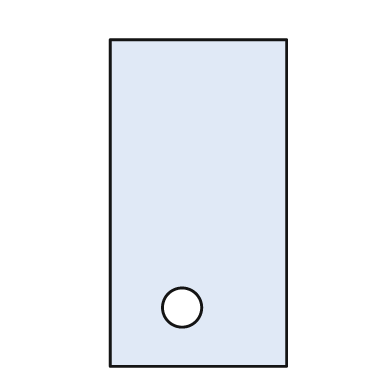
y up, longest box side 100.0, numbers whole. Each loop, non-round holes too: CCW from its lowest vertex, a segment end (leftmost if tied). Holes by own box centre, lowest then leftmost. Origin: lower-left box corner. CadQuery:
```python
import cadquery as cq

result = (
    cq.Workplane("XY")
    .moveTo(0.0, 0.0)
    .lineTo(54.0, 0.0)
    .lineTo(54.0, 100.0)
    .lineTo(0.0, 100.0)
    .close()
    .moveTo(22.0, 18.0)
    .circle(6.0)
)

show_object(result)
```